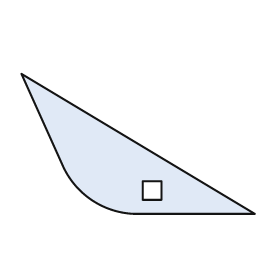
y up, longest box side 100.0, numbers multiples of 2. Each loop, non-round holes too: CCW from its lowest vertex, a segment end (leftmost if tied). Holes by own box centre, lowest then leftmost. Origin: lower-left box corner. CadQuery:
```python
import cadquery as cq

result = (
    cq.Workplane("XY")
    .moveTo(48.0, 0.0)
    .lineTo(100.0, 0.0)
    .lineTo(0.0, 60.0)
    .lineTo(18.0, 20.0)
    .threePointArc((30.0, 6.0), (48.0, 0.0))
    .close()
    .moveTo(52.0, 6.0)
    .lineTo(60.0, 6.0)
    .lineTo(60.0, 14.0)
    .lineTo(52.0, 14.0)
    .close()
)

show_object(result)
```